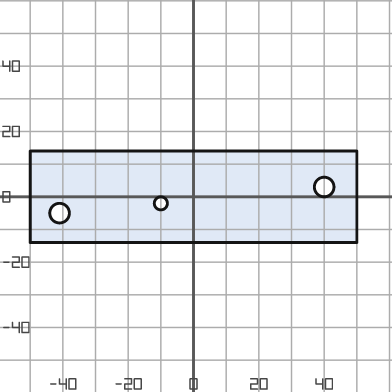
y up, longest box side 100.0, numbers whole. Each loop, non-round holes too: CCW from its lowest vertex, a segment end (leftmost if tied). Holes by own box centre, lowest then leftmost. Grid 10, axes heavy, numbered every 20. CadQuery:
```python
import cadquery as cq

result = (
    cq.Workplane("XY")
    .moveTo(-50.0, -14.0)
    .lineTo(50.0, -14.0)
    .lineTo(50.0, 14.0)
    .lineTo(-50.0, 14.0)
    .close()
    .moveTo(-41.0, -5.0)
    .circle(3.0)
    .moveTo(-10.0, -2.0)
    .circle(2.0)
    .moveTo(40.0, 3.0)
    .circle(3.0)
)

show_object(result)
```